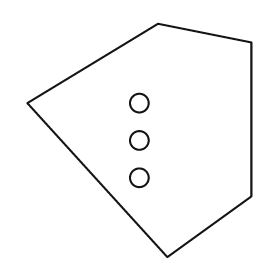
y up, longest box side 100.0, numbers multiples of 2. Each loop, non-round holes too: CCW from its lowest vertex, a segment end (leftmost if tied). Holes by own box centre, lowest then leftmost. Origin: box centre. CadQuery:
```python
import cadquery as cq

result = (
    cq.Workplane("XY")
    .moveTo(12.0, -50.0)
    .lineTo(48.0, -24.0)
    .lineTo(48.0, 42.0)
    .lineTo(8.0, 50.0)
    .lineTo(-48.0, 16.0)
    .close()
    .moveTo(0.0, -16.0)
    .circle(4.0)
    .moveTo(0.0, 0.0)
    .circle(4.0)
    .moveTo(0.0, 16.0)
    .circle(4.0)
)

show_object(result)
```